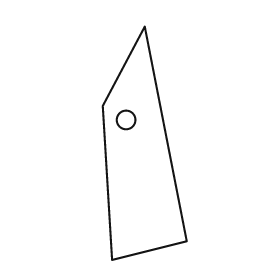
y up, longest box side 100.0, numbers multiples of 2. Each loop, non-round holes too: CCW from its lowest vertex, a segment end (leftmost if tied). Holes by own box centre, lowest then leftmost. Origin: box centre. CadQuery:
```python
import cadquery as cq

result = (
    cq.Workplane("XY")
    .moveTo(-14.0, -50.0)
    .lineTo(18.0, -42.0)
    .lineTo(0.0, 50.0)
    .lineTo(-18.0, 16.0)
    .close()
    .moveTo(-8.0, 10.0)
    .circle(4.0)
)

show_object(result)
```